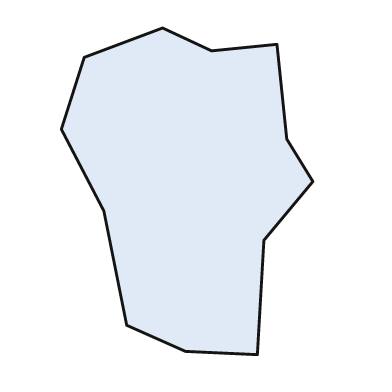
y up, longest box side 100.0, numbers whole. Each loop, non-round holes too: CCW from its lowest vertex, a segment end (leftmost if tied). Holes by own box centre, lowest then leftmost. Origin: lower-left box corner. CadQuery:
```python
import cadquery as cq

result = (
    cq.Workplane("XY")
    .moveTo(60.0, 0.0)
    .lineTo(62.0, 35.0)
    .lineTo(77.0, 53.0)
    .lineTo(69.0, 66.0)
    .lineTo(66.0, 95.0)
    .lineTo(46.0, 93.0)
    .lineTo(31.0, 100.0)
    .lineTo(7.0, 91.0)
    .lineTo(0.0, 69.0)
    .lineTo(13.0, 44.0)
    .lineTo(20.0, 9.0)
    .lineTo(38.0, 1.0)
    .close()
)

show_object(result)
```